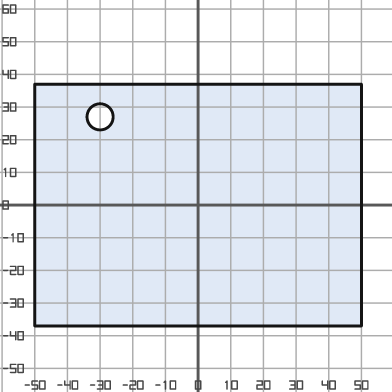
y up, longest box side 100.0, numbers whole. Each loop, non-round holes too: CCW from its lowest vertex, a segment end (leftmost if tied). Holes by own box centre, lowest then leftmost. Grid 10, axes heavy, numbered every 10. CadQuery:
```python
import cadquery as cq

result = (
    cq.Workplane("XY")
    .moveTo(-50.0, -37.0)
    .lineTo(50.0, -37.0)
    .lineTo(50.0, 37.0)
    .lineTo(-50.0, 37.0)
    .close()
    .moveTo(-30.0, 27.0)
    .circle(4.0)
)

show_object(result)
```